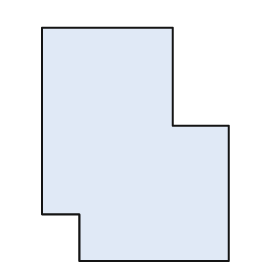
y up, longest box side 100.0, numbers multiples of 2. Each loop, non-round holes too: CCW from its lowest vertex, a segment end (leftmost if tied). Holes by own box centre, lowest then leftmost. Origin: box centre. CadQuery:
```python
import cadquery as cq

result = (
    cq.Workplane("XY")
    .moveTo(-24.0, -50.0)
    .lineTo(40.0, -50.0)
    .lineTo(40.0, 8.0)
    .lineTo(16.0, 8.0)
    .lineTo(16.0, 50.0)
    .lineTo(-40.0, 50.0)
    .lineTo(-40.0, -30.0)
    .lineTo(-24.0, -30.0)
    .close()
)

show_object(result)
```